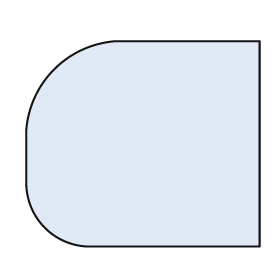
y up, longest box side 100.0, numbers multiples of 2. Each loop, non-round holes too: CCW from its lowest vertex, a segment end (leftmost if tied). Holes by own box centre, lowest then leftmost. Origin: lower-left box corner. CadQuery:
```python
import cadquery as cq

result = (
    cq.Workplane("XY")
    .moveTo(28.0, 0.0)
    .lineTo(100.0, 0.0)
    .lineTo(100.0, 88.0)
    .lineTo(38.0, 88.0)
    .threePointArc((12.0, 76.0), (0.0, 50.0))
    .lineTo(0.0, 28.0)
    .threePointArc((8.0, 8.0), (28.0, 0.0))
    .close()
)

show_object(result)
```